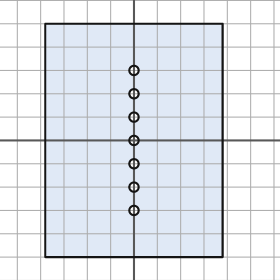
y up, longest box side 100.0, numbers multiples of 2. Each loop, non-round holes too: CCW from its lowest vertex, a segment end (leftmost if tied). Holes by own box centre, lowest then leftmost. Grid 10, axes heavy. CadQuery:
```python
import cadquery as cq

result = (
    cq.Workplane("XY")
    .moveTo(-38.0, -50.0)
    .lineTo(38.0, -50.0)
    .lineTo(38.0, 50.0)
    .lineTo(-38.0, 50.0)
    .close()
    .moveTo(0.0, -30.0)
    .circle(2.0)
    .moveTo(0.0, -20.0)
    .circle(2.0)
    .moveTo(0.0, -10.0)
    .circle(2.0)
    .moveTo(0.0, 0.0)
    .circle(2.0)
    .moveTo(0.0, 10.0)
    .circle(2.0)
    .moveTo(0.0, 20.0)
    .circle(2.0)
    .moveTo(0.0, 30.0)
    .circle(2.0)
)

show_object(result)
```